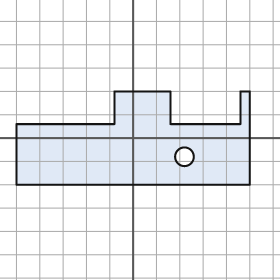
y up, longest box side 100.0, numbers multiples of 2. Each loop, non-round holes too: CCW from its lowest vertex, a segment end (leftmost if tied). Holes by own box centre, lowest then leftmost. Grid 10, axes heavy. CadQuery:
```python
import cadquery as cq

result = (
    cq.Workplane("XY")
    .moveTo(-50.0, -20.0)
    .lineTo(50.0, -20.0)
    .lineTo(50.0, 20.0)
    .lineTo(46.0, 20.0)
    .lineTo(46.0, 6.0)
    .lineTo(16.0, 6.0)
    .lineTo(16.0, 20.0)
    .lineTo(-8.0, 20.0)
    .lineTo(-8.0, 6.0)
    .lineTo(-50.0, 6.0)
    .close()
    .moveTo(22.0, -8.0)
    .circle(4.0)
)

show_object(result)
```